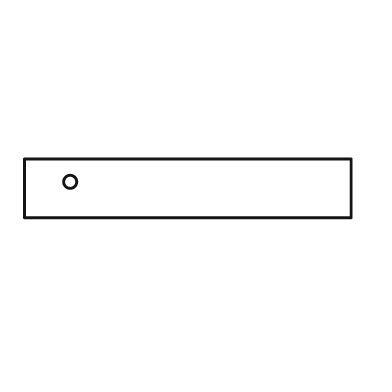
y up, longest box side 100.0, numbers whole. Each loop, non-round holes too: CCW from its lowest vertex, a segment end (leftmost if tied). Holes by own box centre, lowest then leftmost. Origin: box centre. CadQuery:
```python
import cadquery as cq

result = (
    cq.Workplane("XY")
    .moveTo(-50.0, -9.0)
    .lineTo(50.0, -9.0)
    .lineTo(50.0, 9.0)
    .lineTo(-50.0, 9.0)
    .close()
    .moveTo(-36.0, 2.0)
    .circle(2.0)
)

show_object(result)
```